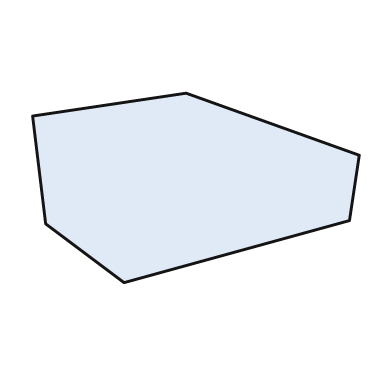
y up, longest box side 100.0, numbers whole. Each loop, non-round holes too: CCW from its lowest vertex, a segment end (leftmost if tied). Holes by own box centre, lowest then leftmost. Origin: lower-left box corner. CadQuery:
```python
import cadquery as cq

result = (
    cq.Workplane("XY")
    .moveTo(28.0, 0.0)
    .lineTo(97.0, 19.0)
    .lineTo(100.0, 39.0)
    .lineTo(47.0, 58.0)
    .lineTo(0.0, 51.0)
    .lineTo(4.0, 18.0)
    .close()
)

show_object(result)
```